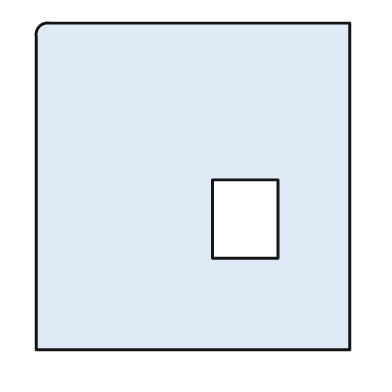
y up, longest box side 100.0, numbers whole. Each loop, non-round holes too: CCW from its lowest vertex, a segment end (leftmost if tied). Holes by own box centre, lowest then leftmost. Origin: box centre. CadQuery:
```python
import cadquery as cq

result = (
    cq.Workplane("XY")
    .moveTo(-48.0, -50.0)
    .lineTo(48.0, -50.0)
    .lineTo(48.0, 50.0)
    .lineTo(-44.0, 50.0)
    .threePointArc((-47.0, 49.0), (-48.0, 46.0))
    .close()
    .moveTo(6.0, -22.0)
    .lineTo(26.0, -22.0)
    .lineTo(26.0, 2.0)
    .lineTo(6.0, 2.0)
    .close()
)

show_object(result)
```